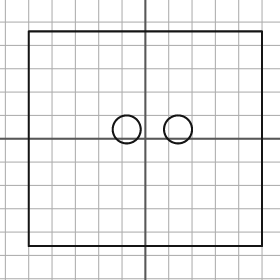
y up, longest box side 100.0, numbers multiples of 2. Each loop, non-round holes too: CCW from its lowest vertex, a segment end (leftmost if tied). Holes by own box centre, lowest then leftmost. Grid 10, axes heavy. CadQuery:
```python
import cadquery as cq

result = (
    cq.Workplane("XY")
    .moveTo(-50.0, -46.0)
    .lineTo(50.0, -46.0)
    .lineTo(50.0, 46.0)
    .lineTo(-50.0, 46.0)
    .close()
    .moveTo(-8.0, 4.0)
    .circle(6.0)
    .moveTo(14.0, 4.0)
    .circle(6.0)
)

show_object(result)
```